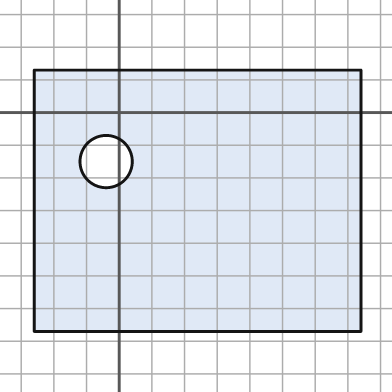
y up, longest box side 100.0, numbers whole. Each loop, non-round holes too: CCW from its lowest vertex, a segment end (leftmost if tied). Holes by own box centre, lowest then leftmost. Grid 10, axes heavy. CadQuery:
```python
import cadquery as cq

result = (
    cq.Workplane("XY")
    .moveTo(-26.0, -67.0)
    .lineTo(74.0, -67.0)
    .lineTo(74.0, 13.0)
    .lineTo(-26.0, 13.0)
    .close()
    .moveTo(-4.0, -15.0)
    .circle(8.0)
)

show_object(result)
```